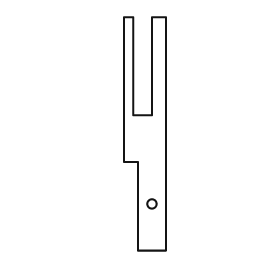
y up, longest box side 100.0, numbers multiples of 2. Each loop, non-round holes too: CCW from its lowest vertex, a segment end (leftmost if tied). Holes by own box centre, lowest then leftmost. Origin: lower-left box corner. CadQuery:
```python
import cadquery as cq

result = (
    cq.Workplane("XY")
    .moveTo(6.0, 0.0)
    .lineTo(18.0, 0.0)
    .lineTo(18.0, 100.0)
    .lineTo(12.0, 100.0)
    .lineTo(12.0, 58.0)
    .lineTo(4.0, 58.0)
    .lineTo(4.0, 100.0)
    .lineTo(0.0, 100.0)
    .lineTo(0.0, 38.0)
    .lineTo(6.0, 38.0)
    .close()
    .moveTo(12.0, 20.0)
    .circle(2.0)
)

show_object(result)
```